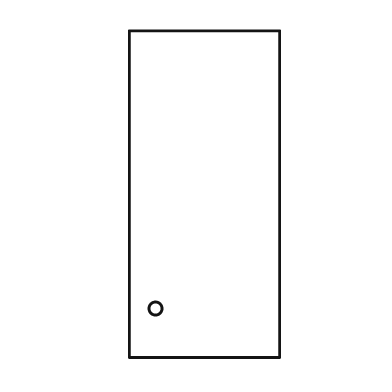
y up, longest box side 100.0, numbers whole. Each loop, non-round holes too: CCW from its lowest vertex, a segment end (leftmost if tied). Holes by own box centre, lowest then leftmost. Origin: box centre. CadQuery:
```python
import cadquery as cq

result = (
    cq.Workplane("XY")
    .moveTo(-23.0, -50.0)
    .lineTo(23.0, -50.0)
    .lineTo(23.0, 50.0)
    .lineTo(-23.0, 50.0)
    .close()
    .moveTo(-15.0, -35.0)
    .circle(2.0)
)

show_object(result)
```